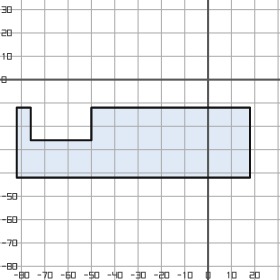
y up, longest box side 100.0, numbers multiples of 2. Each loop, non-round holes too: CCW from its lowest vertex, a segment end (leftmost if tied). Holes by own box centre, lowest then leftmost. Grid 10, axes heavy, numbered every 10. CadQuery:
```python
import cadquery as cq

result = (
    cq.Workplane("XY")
    .moveTo(-82.0, -42.0)
    .lineTo(18.0, -42.0)
    .lineTo(18.0, -12.0)
    .lineTo(-50.0, -12.0)
    .lineTo(-50.0, -26.0)
    .lineTo(-76.0, -26.0)
    .lineTo(-76.0, -12.0)
    .lineTo(-82.0, -12.0)
    .close()
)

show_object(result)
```